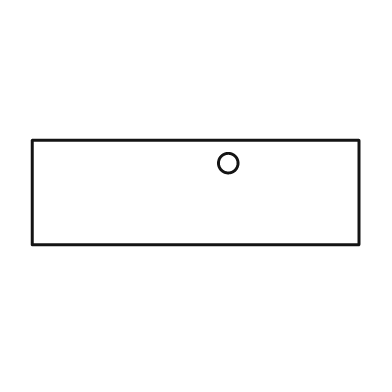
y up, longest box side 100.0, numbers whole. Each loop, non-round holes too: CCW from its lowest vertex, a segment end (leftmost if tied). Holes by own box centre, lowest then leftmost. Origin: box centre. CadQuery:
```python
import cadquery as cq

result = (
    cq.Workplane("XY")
    .moveTo(-50.0, -16.0)
    .lineTo(50.0, -16.0)
    .lineTo(50.0, 16.0)
    .lineTo(-50.0, 16.0)
    .close()
    .moveTo(10.0, 9.0)
    .circle(3.0)
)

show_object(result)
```